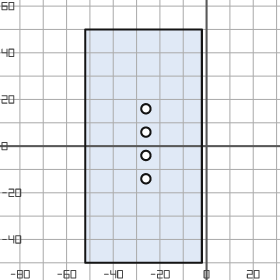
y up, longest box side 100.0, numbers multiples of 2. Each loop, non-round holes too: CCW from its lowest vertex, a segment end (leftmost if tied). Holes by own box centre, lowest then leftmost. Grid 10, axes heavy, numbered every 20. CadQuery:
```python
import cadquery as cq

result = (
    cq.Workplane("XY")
    .moveTo(-52.0, -50.0)
    .lineTo(-2.0, -50.0)
    .lineTo(-2.0, 50.0)
    .lineTo(-52.0, 50.0)
    .close()
    .moveTo(-26.0, -14.0)
    .circle(2.0)
    .moveTo(-26.0, -4.0)
    .circle(2.0)
    .moveTo(-26.0, 6.0)
    .circle(2.0)
    .moveTo(-26.0, 16.0)
    .circle(2.0)
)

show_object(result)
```